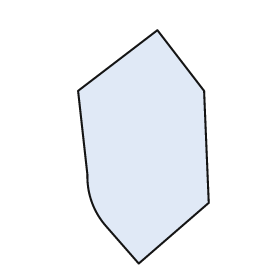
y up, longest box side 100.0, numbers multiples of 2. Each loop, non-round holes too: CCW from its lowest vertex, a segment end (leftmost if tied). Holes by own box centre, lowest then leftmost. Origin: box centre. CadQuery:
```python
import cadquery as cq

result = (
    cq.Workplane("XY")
    .moveTo(-2.0, -50.0)
    .lineTo(28.0, -24.0)
    .lineTo(26.0, 24.0)
    .lineTo(6.0, 50.0)
    .lineTo(-28.0, 24.0)
    .lineTo(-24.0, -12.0)
    .threePointArc((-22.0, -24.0), (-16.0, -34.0))
    .close()
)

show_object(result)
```